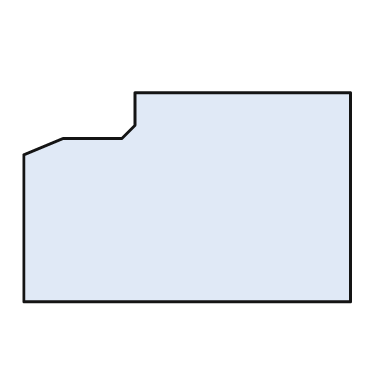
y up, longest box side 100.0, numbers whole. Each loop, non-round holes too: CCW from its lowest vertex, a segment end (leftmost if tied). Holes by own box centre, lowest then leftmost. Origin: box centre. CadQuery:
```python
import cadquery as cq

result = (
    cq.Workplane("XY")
    .moveTo(-50.0, -32.0)
    .lineTo(50.0, -32.0)
    .lineTo(50.0, 32.0)
    .lineTo(-16.0, 32.0)
    .lineTo(-16.0, 22.0)
    .lineTo(-20.0, 18.0)
    .lineTo(-38.0, 18.0)
    .lineTo(-50.0, 13.0)
    .close()
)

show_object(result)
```